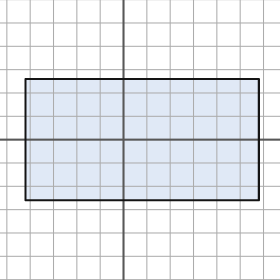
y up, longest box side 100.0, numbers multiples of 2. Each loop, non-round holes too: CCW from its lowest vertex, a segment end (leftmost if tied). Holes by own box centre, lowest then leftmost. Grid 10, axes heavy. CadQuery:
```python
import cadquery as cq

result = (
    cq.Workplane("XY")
    .moveTo(-42.0, -26.0)
    .lineTo(58.0, -26.0)
    .lineTo(58.0, 26.0)
    .lineTo(-42.0, 26.0)
    .close()
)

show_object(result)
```